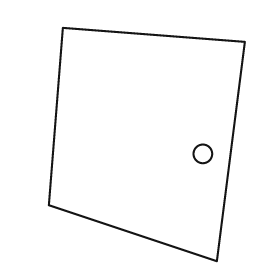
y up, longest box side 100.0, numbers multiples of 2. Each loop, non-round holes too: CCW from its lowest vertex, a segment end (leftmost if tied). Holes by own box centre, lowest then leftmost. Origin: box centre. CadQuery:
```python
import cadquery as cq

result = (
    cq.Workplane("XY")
    .moveTo(30.0, -50.0)
    .lineTo(42.0, 44.0)
    .lineTo(-36.0, 50.0)
    .lineTo(-42.0, -26.0)
    .close()
    .moveTo(24.0, -4.0)
    .circle(4.0)
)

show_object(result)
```